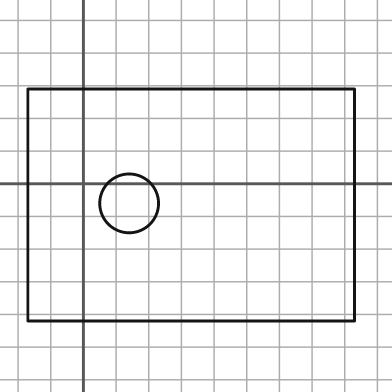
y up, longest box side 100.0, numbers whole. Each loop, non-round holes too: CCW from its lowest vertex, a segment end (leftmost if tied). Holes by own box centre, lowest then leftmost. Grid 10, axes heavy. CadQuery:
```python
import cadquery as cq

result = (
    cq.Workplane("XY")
    .moveTo(-17.0, -42.0)
    .lineTo(83.0, -42.0)
    .lineTo(83.0, 29.0)
    .lineTo(-17.0, 29.0)
    .close()
    .moveTo(14.0, -6.0)
    .circle(9.0)
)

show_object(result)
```